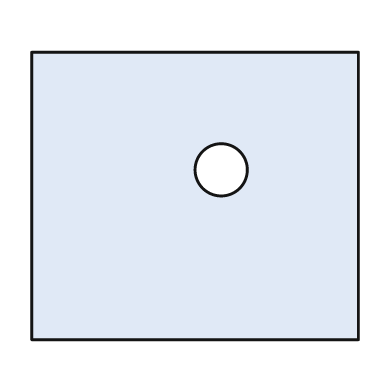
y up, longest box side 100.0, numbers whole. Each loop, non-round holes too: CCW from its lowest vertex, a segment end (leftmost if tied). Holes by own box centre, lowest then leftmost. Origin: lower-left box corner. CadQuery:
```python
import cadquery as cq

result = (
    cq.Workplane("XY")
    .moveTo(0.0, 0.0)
    .lineTo(100.0, 0.0)
    .lineTo(100.0, 88.0)
    .lineTo(0.0, 88.0)
    .close()
    .moveTo(58.0, 52.0)
    .circle(8.0)
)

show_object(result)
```